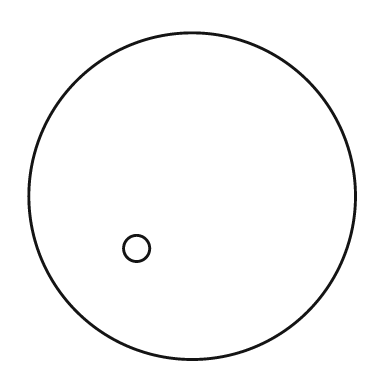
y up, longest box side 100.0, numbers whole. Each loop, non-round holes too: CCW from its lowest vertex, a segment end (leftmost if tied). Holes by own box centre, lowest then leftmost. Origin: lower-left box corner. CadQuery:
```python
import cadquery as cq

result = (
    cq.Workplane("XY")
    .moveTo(50.0, 50.0)
    .circle(50.0)
    .moveTo(33.0, 34.0)
    .circle(4.0)
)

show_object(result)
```